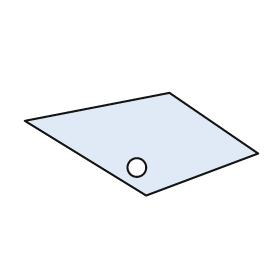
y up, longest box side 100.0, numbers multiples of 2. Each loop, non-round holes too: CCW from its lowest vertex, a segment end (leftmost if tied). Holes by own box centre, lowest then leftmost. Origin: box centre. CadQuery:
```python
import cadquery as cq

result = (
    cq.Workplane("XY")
    .moveTo(2.0, -22.0)
    .lineTo(50.0, -4.0)
    .lineTo(12.0, 22.0)
    .lineTo(-50.0, 10.0)
    .close()
    .moveTo(-2.0, -10.0)
    .circle(4.0)
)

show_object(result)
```